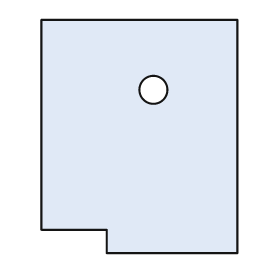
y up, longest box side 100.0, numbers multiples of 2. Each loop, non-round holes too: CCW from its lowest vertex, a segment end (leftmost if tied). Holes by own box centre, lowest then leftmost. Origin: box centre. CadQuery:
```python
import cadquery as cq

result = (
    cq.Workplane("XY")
    .moveTo(-14.0, -50.0)
    .lineTo(42.0, -50.0)
    .lineTo(42.0, 50.0)
    .lineTo(-42.0, 50.0)
    .lineTo(-42.0, -40.0)
    .lineTo(-14.0, -40.0)
    .close()
    .moveTo(6.0, 20.0)
    .circle(6.0)
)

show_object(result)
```